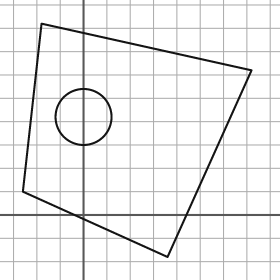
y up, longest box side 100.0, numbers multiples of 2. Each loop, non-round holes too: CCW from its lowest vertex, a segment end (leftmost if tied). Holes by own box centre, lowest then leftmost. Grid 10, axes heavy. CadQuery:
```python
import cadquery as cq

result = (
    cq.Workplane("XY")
    .moveTo(36.0, -18.0)
    .lineTo(72.0, 62.0)
    .lineTo(-18.0, 82.0)
    .lineTo(-26.0, 10.0)
    .close()
    .moveTo(0.0, 42.0)
    .circle(12.0)
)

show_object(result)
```